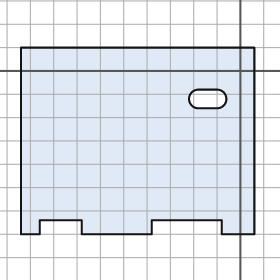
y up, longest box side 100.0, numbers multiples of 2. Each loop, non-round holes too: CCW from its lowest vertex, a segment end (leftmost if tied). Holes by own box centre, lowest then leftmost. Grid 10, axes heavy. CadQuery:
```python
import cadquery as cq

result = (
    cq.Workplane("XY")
    .moveTo(-94.0, -70.0)
    .lineTo(-86.0, -70.0)
    .lineTo(-86.0, -64.0)
    .lineTo(-68.0, -64.0)
    .lineTo(-68.0, -70.0)
    .lineTo(-38.0, -70.0)
    .lineTo(-38.0, -64.0)
    .lineTo(-8.0, -64.0)
    .lineTo(-8.0, -70.0)
    .lineTo(6.0, -70.0)
    .lineTo(6.0, 10.0)
    .lineTo(-94.0, 10.0)
    .close()
    .moveTo(-18.0, -16.0)
    .lineTo(-10.0, -16.0)
    .threePointArc((-6.0, -12.0), (-10.0, -8.0))
    .lineTo(-18.0, -8.0)
    .threePointArc((-22.0, -12.0), (-18.0, -16.0))
    .close()
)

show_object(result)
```